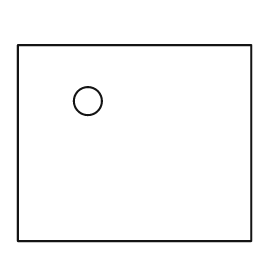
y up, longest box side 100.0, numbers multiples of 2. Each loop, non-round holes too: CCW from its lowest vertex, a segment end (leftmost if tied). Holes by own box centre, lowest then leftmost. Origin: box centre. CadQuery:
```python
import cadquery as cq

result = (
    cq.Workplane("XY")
    .moveTo(-50.0, -42.0)
    .lineTo(50.0, -42.0)
    .lineTo(50.0, 42.0)
    .lineTo(-50.0, 42.0)
    .close()
    .moveTo(-20.0, 18.0)
    .circle(6.0)
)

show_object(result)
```